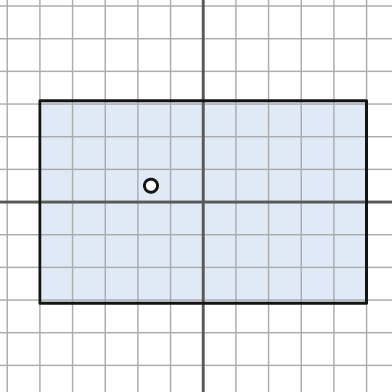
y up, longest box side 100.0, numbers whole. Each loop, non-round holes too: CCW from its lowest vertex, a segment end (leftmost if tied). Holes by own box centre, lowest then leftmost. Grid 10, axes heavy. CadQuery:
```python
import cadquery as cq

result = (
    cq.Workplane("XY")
    .moveTo(-50.0, -31.0)
    .lineTo(50.0, -31.0)
    .lineTo(50.0, 31.0)
    .lineTo(-50.0, 31.0)
    .close()
    .moveTo(-16.0, 5.0)
    .circle(2.0)
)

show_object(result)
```